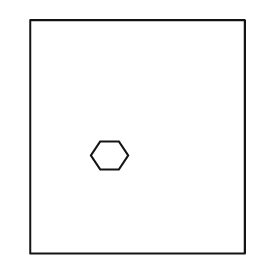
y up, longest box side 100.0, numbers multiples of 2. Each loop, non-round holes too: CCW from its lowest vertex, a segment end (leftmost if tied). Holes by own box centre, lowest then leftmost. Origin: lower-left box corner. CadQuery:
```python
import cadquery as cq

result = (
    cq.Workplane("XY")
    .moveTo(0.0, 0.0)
    .lineTo(92.0, 0.0)
    .lineTo(92.0, 100.0)
    .lineTo(0.0, 100.0)
    .close()
    .moveTo(30.0, 36.0)
    .lineTo(38.0, 36.0)
    .lineTo(42.0, 42.0)
    .lineTo(38.0, 48.0)
    .lineTo(30.0, 48.0)
    .lineTo(26.0, 42.0)
    .close()
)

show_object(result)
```